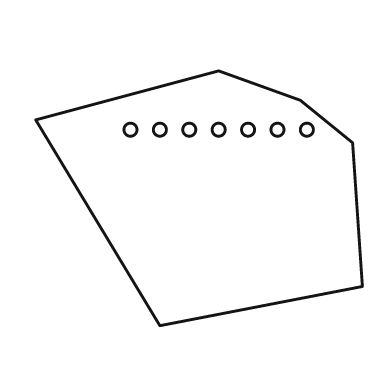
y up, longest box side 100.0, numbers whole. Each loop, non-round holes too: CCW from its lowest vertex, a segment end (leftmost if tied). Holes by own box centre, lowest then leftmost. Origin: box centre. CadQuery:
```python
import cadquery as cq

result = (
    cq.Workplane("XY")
    .moveTo(-12.0, -39.0)
    .lineTo(50.0, -27.0)
    .lineTo(47.0, 17.0)
    .lineTo(31.0, 30.0)
    .lineTo(6.0, 39.0)
    .lineTo(-50.0, 24.0)
    .close()
    .moveTo(-21.0, 21.0)
    .circle(2.0)
    .moveTo(-12.0, 21.0)
    .circle(2.0)
    .moveTo(-3.0, 21.0)
    .circle(2.0)
    .moveTo(6.0, 21.0)
    .circle(2.0)
    .moveTo(15.0, 21.0)
    .circle(2.0)
    .moveTo(24.0, 21.0)
    .circle(2.0)
    .moveTo(33.0, 21.0)
    .circle(2.0)
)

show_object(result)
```